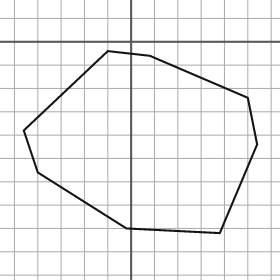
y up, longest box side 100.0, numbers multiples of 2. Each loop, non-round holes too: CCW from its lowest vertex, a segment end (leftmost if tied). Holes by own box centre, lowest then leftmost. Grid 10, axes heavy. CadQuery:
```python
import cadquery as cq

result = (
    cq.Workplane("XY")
    .moveTo(38.0, -82.0)
    .lineTo(54.0, -44.0)
    .lineTo(50.0, -24.0)
    .lineTo(8.0, -6.0)
    .lineTo(-10.0, -4.0)
    .lineTo(-46.0, -38.0)
    .lineTo(-40.0, -56.0)
    .lineTo(-2.0, -80.0)
    .close()
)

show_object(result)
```